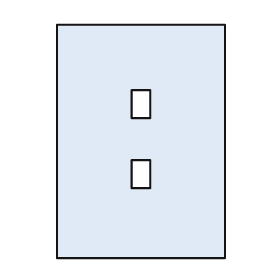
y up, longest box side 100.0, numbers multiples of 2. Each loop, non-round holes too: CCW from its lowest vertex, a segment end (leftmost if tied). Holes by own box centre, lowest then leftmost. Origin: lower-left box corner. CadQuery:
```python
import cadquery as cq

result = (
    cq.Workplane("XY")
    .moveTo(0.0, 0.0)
    .lineTo(72.0, 0.0)
    .lineTo(72.0, 100.0)
    .lineTo(0.0, 100.0)
    .close()
    .moveTo(32.0, 30.0)
    .lineTo(40.0, 30.0)
    .lineTo(40.0, 42.0)
    .lineTo(32.0, 42.0)
    .close()
    .moveTo(32.0, 60.0)
    .lineTo(40.0, 60.0)
    .lineTo(40.0, 72.0)
    .lineTo(32.0, 72.0)
    .close()
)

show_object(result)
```